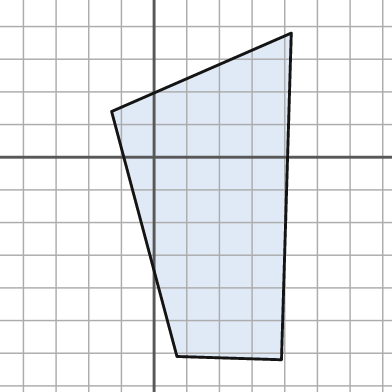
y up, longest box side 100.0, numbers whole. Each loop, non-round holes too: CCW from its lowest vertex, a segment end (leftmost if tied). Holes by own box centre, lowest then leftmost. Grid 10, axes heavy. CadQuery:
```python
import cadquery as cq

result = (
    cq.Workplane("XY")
    .moveTo(39.0, -62.0)
    .lineTo(42.0, 38.0)
    .lineTo(-13.0, 14.0)
    .lineTo(7.0, -61.0)
    .close()
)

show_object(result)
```